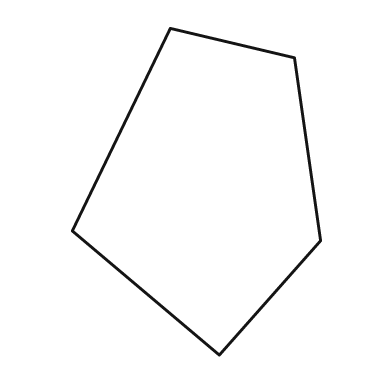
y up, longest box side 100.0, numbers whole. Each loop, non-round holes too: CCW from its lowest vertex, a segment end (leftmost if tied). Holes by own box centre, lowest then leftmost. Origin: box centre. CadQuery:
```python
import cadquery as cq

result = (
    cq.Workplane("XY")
    .moveTo(7.0, -50.0)
    .lineTo(38.0, -15.0)
    .lineTo(30.0, 41.0)
    .lineTo(-8.0, 50.0)
    .lineTo(-38.0, -12.0)
    .close()
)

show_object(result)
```